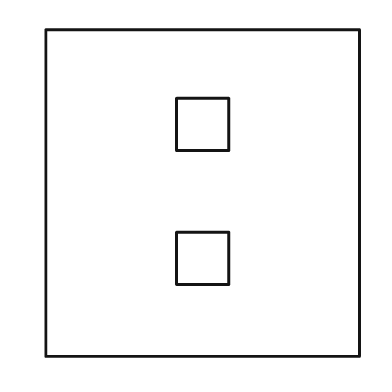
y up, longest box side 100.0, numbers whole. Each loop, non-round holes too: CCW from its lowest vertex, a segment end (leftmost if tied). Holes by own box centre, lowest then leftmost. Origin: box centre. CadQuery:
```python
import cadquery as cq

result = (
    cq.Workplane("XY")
    .moveTo(-48.0, -50.0)
    .lineTo(48.0, -50.0)
    .lineTo(48.0, 50.0)
    .lineTo(-48.0, 50.0)
    .close()
    .moveTo(-8.0, -28.0)
    .lineTo(8.0, -28.0)
    .lineTo(8.0, -12.0)
    .lineTo(-8.0, -12.0)
    .close()
    .moveTo(-8.0, 13.0)
    .lineTo(8.0, 13.0)
    .lineTo(8.0, 29.0)
    .lineTo(-8.0, 29.0)
    .close()
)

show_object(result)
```